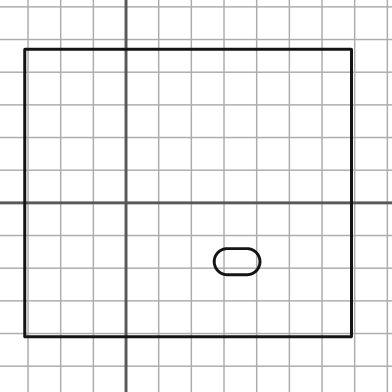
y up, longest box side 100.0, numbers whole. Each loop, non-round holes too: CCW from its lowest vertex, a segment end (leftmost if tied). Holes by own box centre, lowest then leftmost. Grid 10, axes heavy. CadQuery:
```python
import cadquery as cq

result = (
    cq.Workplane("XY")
    .moveTo(-31.0, -41.0)
    .lineTo(69.0, -41.0)
    .lineTo(69.0, 47.0)
    .lineTo(-31.0, 47.0)
    .close()
    .moveTo(31.0, -22.0)
    .lineTo(37.0, -22.0)
    .threePointArc((41.0, -18.0), (37.0, -14.0))
    .lineTo(31.0, -14.0)
    .threePointArc((27.0, -18.0), (31.0, -22.0))
    .close()
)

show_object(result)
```